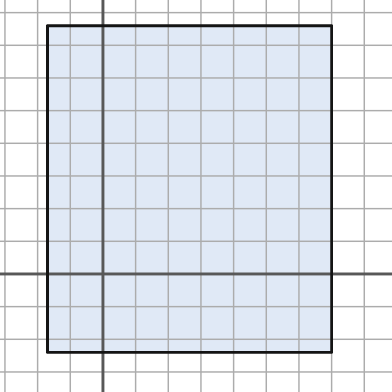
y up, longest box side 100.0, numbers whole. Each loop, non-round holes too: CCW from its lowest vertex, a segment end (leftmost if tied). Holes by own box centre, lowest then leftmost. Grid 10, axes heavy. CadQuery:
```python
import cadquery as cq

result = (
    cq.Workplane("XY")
    .moveTo(-17.0, -24.0)
    .lineTo(70.0, -24.0)
    .lineTo(70.0, 76.0)
    .lineTo(-17.0, 76.0)
    .close()
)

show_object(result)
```